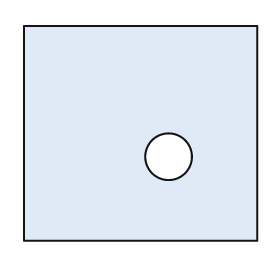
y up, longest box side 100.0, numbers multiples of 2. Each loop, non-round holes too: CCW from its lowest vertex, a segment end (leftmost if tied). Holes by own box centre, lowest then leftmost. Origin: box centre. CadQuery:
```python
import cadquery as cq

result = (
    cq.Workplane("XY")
    .moveTo(-50.0, -46.0)
    .lineTo(50.0, -46.0)
    .lineTo(50.0, 46.0)
    .lineTo(-50.0, 46.0)
    .close()
    .moveTo(12.0, -10.0)
    .circle(10.0)
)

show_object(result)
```